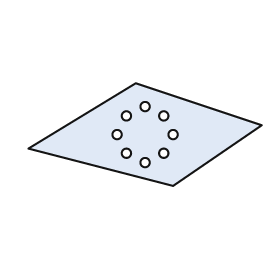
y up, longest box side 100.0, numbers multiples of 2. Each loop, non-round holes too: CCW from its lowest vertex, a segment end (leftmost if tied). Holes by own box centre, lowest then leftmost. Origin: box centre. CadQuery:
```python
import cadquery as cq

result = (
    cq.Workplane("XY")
    .moveTo(12.0, -22.0)
    .lineTo(50.0, 4.0)
    .lineTo(-4.0, 22.0)
    .lineTo(-50.0, -6.0)
    .close()
    .moveTo(0.0, -12.0)
    .circle(2.0)
    .moveTo(-8.0, -8.0)
    .circle(2.0)
    .moveTo(8.0, -8.0)
    .circle(2.0)
    .moveTo(-12.0, 0.0)
    .circle(2.0)
    .moveTo(12.0, 0.0)
    .circle(2.0)
    .moveTo(-8.0, 8.0)
    .circle(2.0)
    .moveTo(8.0, 8.0)
    .circle(2.0)
    .moveTo(0.0, 12.0)
    .circle(2.0)
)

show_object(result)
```